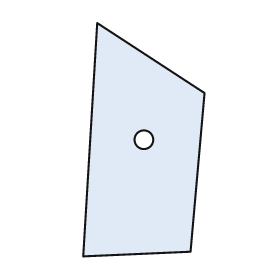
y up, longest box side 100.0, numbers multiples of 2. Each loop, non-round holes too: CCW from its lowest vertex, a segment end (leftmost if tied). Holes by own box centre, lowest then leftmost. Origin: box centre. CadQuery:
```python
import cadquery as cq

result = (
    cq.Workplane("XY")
    .moveTo(-26.0, -50.0)
    .lineTo(20.0, -48.0)
    .lineTo(26.0, 20.0)
    .lineTo(-20.0, 50.0)
    .close()
    .moveTo(0.0, 0.0)
    .circle(4.0)
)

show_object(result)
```